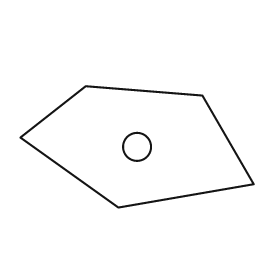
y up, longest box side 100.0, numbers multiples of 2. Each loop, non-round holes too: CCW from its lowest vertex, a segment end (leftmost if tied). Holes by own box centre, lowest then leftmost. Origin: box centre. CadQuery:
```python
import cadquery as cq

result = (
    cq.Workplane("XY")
    .moveTo(-8.0, -26.0)
    .lineTo(50.0, -16.0)
    .lineTo(28.0, 22.0)
    .lineTo(-22.0, 26.0)
    .lineTo(-50.0, 4.0)
    .close()
    .moveTo(0.0, 0.0)
    .circle(6.0)
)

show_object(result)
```